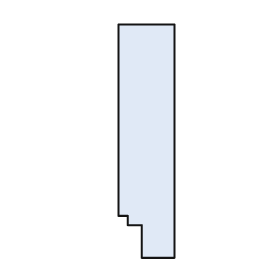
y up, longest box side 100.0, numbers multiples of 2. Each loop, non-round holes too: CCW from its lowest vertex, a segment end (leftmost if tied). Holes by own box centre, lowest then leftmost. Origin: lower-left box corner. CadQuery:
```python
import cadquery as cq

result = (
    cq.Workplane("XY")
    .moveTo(10.0, 0.0)
    .lineTo(24.0, 0.0)
    .lineTo(24.0, 100.0)
    .lineTo(0.0, 100.0)
    .lineTo(0.0, 18.0)
    .lineTo(4.0, 18.0)
    .lineTo(4.0, 14.0)
    .lineTo(10.0, 14.0)
    .close()
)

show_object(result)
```